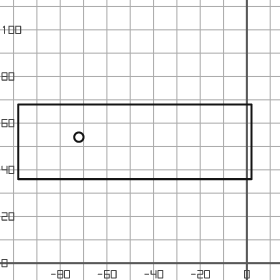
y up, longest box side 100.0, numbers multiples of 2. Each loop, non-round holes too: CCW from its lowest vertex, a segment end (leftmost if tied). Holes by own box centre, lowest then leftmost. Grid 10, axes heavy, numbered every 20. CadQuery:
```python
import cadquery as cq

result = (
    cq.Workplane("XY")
    .moveTo(-98.0, 36.0)
    .lineTo(2.0, 36.0)
    .lineTo(2.0, 68.0)
    .lineTo(-98.0, 68.0)
    .close()
    .moveTo(-72.0, 54.0)
    .circle(2.0)
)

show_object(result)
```